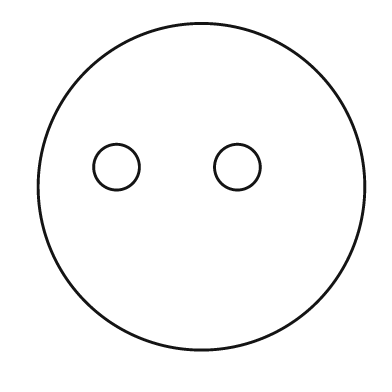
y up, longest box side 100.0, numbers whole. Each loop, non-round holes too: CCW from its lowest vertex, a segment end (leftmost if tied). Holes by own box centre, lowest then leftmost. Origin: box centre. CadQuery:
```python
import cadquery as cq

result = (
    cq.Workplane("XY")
    .moveTo(0.0, 0.0)
    .circle(50.0)
    .moveTo(-26.0, 6.0)
    .circle(7.0)
    .moveTo(11.0, 6.0)
    .circle(7.0)
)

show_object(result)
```